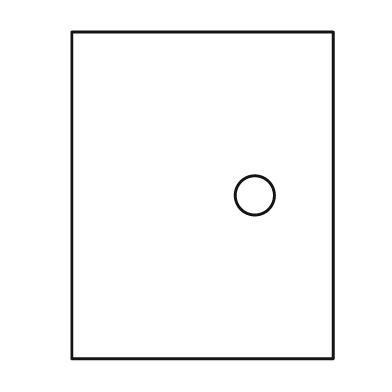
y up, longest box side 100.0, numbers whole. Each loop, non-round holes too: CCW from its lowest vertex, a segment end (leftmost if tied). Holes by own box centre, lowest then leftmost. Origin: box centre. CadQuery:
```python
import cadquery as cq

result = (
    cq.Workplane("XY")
    .moveTo(-40.0, -50.0)
    .lineTo(40.0, -50.0)
    .lineTo(40.0, 50.0)
    .lineTo(-40.0, 50.0)
    .close()
    .moveTo(16.0, 0.0)
    .circle(6.0)
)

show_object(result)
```